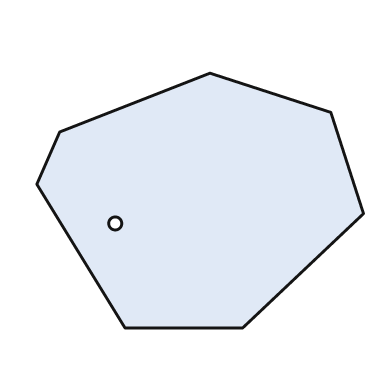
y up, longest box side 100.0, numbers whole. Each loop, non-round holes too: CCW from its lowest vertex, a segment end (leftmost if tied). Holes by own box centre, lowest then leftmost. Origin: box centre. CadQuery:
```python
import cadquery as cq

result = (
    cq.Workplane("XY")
    .moveTo(-23.0, -39.0)
    .lineTo(13.0, -39.0)
    .lineTo(50.0, -4.0)
    .lineTo(40.0, 27.0)
    .lineTo(3.0, 39.0)
    .lineTo(-43.0, 21.0)
    .lineTo(-50.0, 5.0)
    .close()
    .moveTo(-26.0, -7.0)
    .circle(2.0)
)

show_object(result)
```